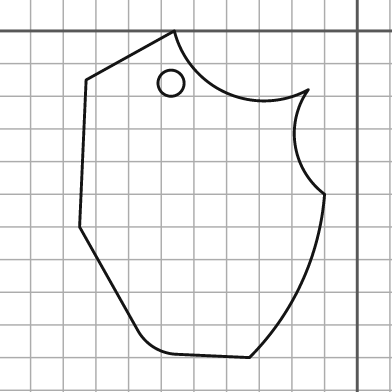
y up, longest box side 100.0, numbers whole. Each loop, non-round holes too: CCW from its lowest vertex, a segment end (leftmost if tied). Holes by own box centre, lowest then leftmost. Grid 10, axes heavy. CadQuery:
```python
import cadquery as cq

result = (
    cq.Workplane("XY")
    .moveTo(-33.0, -100.0)
    .threePointArc((-17.0, -77.0), (-10.0, -50.0))
    .threePointArc((-19.0, -35.0), (-15.0, -18.0))
    .threePointArc((-40.0, -19.0), (-56.0, 0.0))
    .lineTo(-83.0, -15.0)
    .lineTo(-85.0, -60.0)
    .lineTo(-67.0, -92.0)
    .threePointArc((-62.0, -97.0), (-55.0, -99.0))
    .close()
    .moveTo(-57.0, -16.0)
    .circle(4.0)
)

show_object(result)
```